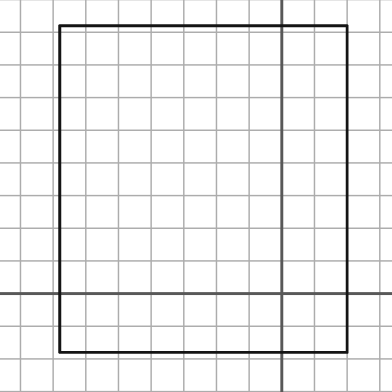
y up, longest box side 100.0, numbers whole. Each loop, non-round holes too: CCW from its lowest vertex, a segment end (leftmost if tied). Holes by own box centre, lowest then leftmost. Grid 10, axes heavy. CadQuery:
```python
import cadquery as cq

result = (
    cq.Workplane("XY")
    .moveTo(-68.0, -18.0)
    .lineTo(20.0, -18.0)
    .lineTo(20.0, 82.0)
    .lineTo(-68.0, 82.0)
    .close()
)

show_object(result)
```